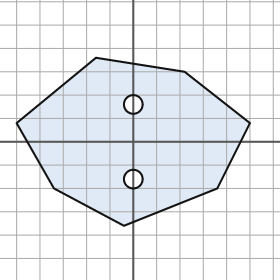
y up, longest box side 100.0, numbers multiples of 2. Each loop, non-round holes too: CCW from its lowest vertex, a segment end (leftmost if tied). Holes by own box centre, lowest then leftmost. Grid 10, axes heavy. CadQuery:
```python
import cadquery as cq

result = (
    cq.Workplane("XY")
    .moveTo(-4.0, -36.0)
    .lineTo(36.0, -20.0)
    .lineTo(50.0, 8.0)
    .lineTo(22.0, 30.0)
    .lineTo(-16.0, 36.0)
    .lineTo(-50.0, 8.0)
    .lineTo(-34.0, -20.0)
    .close()
    .moveTo(0.0, -16.0)
    .circle(4.0)
    .moveTo(0.0, 16.0)
    .circle(4.0)
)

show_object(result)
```